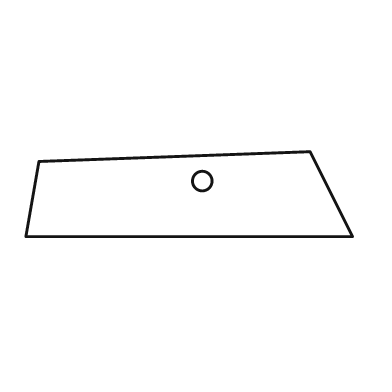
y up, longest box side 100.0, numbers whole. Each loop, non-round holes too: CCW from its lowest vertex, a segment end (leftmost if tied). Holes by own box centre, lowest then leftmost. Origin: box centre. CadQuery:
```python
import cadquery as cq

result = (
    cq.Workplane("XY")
    .moveTo(-50.0, -13.0)
    .lineTo(50.0, -13.0)
    .lineTo(37.0, 13.0)
    .lineTo(-46.0, 10.0)
    .close()
    .moveTo(4.0, 4.0)
    .circle(3.0)
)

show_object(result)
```